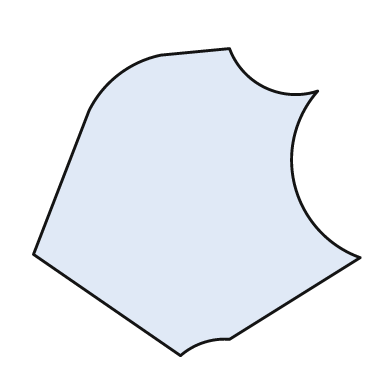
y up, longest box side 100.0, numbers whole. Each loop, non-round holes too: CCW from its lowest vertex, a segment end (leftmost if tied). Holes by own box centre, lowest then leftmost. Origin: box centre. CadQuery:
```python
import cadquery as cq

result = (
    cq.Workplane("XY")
    .moveTo(-5.0, -47.0)
    .threePointArc((2.0, -43.0), (10.0, -42.0))
    .lineTo(50.0, -17.0)
    .threePointArc((30.0, 5.0), (37.0, 34.0))
    .threePointArc((21.0, 35.0), (10.0, 47.0))
    .lineTo(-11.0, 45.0)
    .threePointArc((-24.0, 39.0), (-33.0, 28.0))
    .lineTo(-50.0, -16.0)
    .close()
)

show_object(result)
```